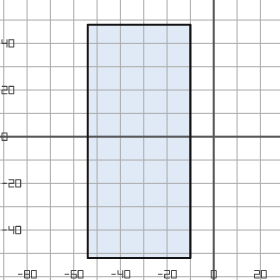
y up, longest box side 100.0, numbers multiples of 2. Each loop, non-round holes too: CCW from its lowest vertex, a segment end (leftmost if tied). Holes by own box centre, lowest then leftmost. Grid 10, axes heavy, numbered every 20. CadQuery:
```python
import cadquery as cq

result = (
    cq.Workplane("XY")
    .moveTo(-54.0, -52.0)
    .lineTo(-10.0, -52.0)
    .lineTo(-10.0, 48.0)
    .lineTo(-54.0, 48.0)
    .close()
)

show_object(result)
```